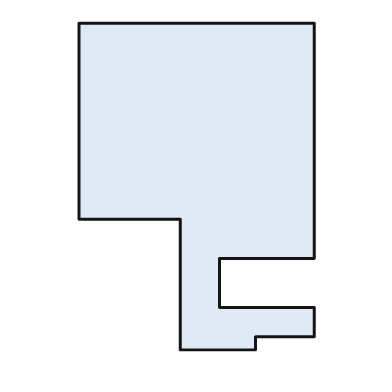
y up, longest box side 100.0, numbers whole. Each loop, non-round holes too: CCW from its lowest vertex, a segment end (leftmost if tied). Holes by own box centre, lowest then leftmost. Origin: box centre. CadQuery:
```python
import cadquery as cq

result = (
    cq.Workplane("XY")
    .moveTo(-5.0, -50.0)
    .lineTo(18.0, -50.0)
    .lineTo(18.0, -46.0)
    .lineTo(36.0, -46.0)
    .lineTo(36.0, -37.0)
    .lineTo(7.0, -37.0)
    .lineTo(7.0, -22.0)
    .lineTo(36.0, -22.0)
    .lineTo(36.0, 50.0)
    .lineTo(-36.0, 50.0)
    .lineTo(-36.0, -10.0)
    .lineTo(-5.0, -10.0)
    .close()
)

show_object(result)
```